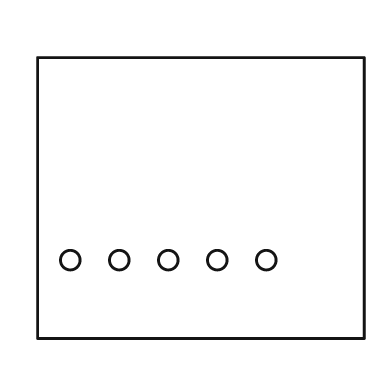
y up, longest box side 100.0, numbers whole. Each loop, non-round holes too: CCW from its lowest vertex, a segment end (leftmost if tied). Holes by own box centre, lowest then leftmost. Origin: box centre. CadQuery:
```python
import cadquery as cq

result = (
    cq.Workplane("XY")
    .moveTo(-50.0, -43.0)
    .lineTo(50.0, -43.0)
    .lineTo(50.0, 43.0)
    .lineTo(-50.0, 43.0)
    .close()
    .moveTo(-40.0, -19.0)
    .circle(3.0)
    .moveTo(-25.0, -19.0)
    .circle(3.0)
    .moveTo(-10.0, -19.0)
    .circle(3.0)
    .moveTo(5.0, -19.0)
    .circle(3.0)
    .moveTo(20.0, -19.0)
    .circle(3.0)
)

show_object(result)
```